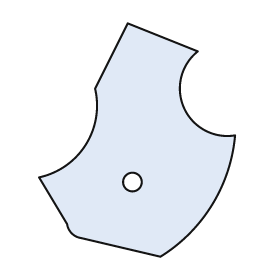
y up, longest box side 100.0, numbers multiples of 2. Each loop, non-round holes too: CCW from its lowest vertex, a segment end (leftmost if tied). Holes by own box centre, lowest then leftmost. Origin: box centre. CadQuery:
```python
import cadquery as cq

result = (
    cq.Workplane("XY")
    .moveTo(10.0, -50.0)
    .threePointArc((32.0, -28.0), (42.0, 2.0))
    .threePointArc((20.0, 14.0), (26.0, 38.0))
    .lineTo(-4.0, 50.0)
    .lineTo(-18.0, 22.0)
    .threePointArc((-22.0, -2.0), (-42.0, -16.0))
    .lineTo(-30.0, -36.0)
    .threePointArc((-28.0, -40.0), (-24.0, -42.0))
    .close()
    .moveTo(-2.0, -18.0)
    .circle(4.0)
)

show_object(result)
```